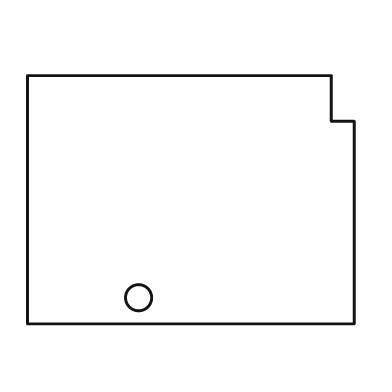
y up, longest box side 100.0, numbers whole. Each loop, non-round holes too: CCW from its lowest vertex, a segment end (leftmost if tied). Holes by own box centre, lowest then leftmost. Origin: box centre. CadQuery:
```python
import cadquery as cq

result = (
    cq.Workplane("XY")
    .moveTo(-50.0, -38.0)
    .lineTo(50.0, -38.0)
    .lineTo(50.0, 24.0)
    .lineTo(43.0, 24.0)
    .lineTo(43.0, 38.0)
    .lineTo(-50.0, 38.0)
    .close()
    .moveTo(-16.0, -30.0)
    .circle(4.0)
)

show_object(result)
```